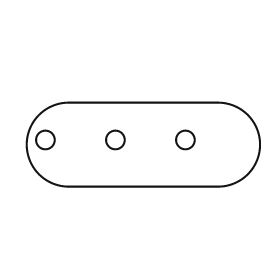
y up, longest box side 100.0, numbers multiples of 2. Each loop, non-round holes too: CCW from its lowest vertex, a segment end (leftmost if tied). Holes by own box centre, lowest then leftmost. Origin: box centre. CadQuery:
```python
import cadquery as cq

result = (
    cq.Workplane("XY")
    .moveTo(-32.0, -18.0)
    .lineTo(32.0, -18.0)
    .threePointArc((50.0, 0.0), (32.0, 18.0))
    .lineTo(-32.0, 18.0)
    .threePointArc((-50.0, 0.0), (-32.0, -18.0))
    .close()
    .moveTo(-42.0, 2.0)
    .circle(4.0)
    .moveTo(-12.0, 2.0)
    .circle(4.0)
    .moveTo(18.0, 2.0)
    .circle(4.0)
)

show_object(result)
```